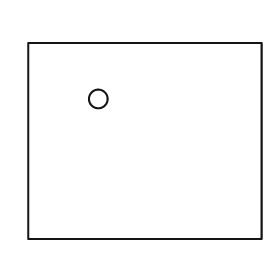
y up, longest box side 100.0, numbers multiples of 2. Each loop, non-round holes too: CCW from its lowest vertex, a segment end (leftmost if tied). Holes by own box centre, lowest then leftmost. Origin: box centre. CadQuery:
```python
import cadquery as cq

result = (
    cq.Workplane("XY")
    .moveTo(-50.0, -42.0)
    .lineTo(50.0, -42.0)
    .lineTo(50.0, 42.0)
    .lineTo(-50.0, 42.0)
    .close()
    .moveTo(-20.0, 18.0)
    .circle(4.0)
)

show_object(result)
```